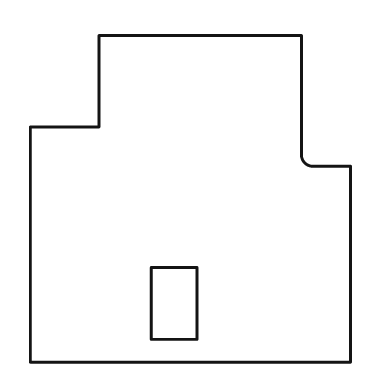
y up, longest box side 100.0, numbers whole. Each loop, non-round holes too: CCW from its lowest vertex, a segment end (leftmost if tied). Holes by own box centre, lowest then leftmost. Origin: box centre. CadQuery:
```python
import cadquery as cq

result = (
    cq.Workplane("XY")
    .moveTo(-49.0, -50.0)
    .lineTo(49.0, -50.0)
    .lineTo(49.0, 10.0)
    .lineTo(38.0, 10.0)
    .threePointArc((35.0, 11.0), (34.0, 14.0))
    .lineTo(34.0, 50.0)
    .lineTo(-28.0, 50.0)
    .lineTo(-28.0, 22.0)
    .lineTo(-49.0, 22.0)
    .close()
    .moveTo(-12.0, -43.0)
    .lineTo(2.0, -43.0)
    .lineTo(2.0, -21.0)
    .lineTo(-12.0, -21.0)
    .close()
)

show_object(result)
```